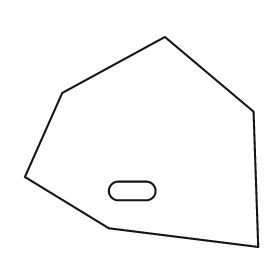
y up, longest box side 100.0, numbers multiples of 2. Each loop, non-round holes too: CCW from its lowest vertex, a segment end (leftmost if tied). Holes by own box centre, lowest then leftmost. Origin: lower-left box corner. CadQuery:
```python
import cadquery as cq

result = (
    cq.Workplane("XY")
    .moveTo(100.0, 0.0)
    .lineTo(98.0, 58.0)
    .lineTo(60.0, 90.0)
    .lineTo(16.0, 66.0)
    .lineTo(0.0, 30.0)
    .lineTo(36.0, 8.0)
    .close()
    .moveTo(40.0, 20.0)
    .lineTo(52.0, 20.0)
    .threePointArc((56.0, 24.0), (52.0, 28.0))
    .lineTo(40.0, 28.0)
    .threePointArc((36.0, 24.0), (40.0, 20.0))
    .close()
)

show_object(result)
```